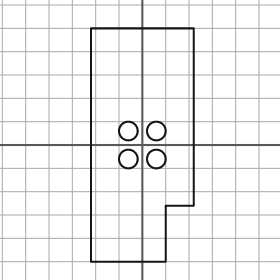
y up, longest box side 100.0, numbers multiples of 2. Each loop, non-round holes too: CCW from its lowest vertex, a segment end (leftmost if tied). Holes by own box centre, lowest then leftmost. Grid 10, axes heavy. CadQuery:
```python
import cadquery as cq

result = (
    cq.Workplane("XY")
    .moveTo(-22.0, -50.0)
    .lineTo(10.0, -50.0)
    .lineTo(10.0, -26.0)
    .lineTo(22.0, -26.0)
    .lineTo(22.0, 50.0)
    .lineTo(-22.0, 50.0)
    .close()
    .moveTo(-6.0, -6.0)
    .circle(4.0)
    .moveTo(6.0, -6.0)
    .circle(4.0)
    .moveTo(-6.0, 6.0)
    .circle(4.0)
    .moveTo(6.0, 6.0)
    .circle(4.0)
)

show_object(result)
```